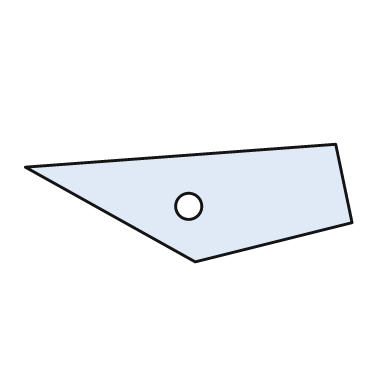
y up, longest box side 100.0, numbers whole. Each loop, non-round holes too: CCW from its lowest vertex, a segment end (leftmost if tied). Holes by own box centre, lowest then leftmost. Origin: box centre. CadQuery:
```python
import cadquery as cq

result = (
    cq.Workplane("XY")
    .moveTo(2.0, -18.0)
    .lineTo(50.0, -6.0)
    .lineTo(45.0, 18.0)
    .lineTo(-50.0, 11.0)
    .close()
    .moveTo(0.0, -1.0)
    .circle(4.0)
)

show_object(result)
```